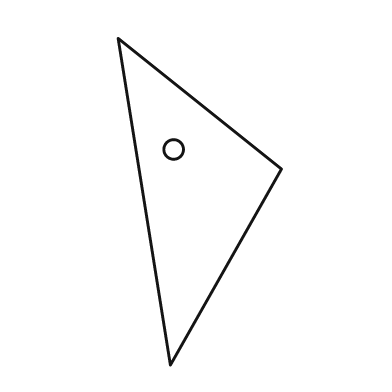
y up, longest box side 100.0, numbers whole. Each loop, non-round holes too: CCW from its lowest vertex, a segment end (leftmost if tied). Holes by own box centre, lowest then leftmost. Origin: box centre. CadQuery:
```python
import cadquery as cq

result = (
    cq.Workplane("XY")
    .moveTo(-9.0, -50.0)
    .lineTo(25.0, 10.0)
    .lineTo(-25.0, 50.0)
    .close()
    .moveTo(-8.0, 16.0)
    .circle(3.0)
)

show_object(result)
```